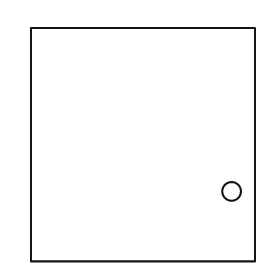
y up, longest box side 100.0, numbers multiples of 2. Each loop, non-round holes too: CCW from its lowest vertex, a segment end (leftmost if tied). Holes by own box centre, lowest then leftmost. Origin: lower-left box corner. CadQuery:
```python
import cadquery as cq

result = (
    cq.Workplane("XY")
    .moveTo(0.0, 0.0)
    .lineTo(96.0, 0.0)
    .lineTo(96.0, 100.0)
    .lineTo(0.0, 100.0)
    .close()
    .moveTo(86.0, 30.0)
    .circle(4.0)
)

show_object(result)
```